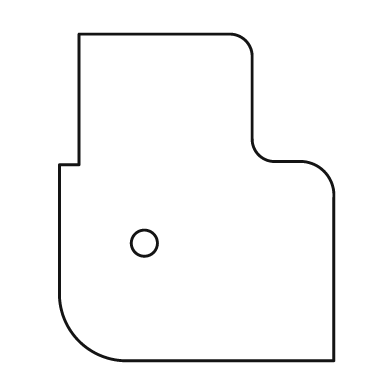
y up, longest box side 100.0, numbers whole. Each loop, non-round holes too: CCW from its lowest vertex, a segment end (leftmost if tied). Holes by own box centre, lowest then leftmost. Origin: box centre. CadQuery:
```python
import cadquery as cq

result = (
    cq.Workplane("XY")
    .moveTo(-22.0, -50.0)
    .lineTo(42.0, -50.0)
    .lineTo(42.0, 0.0)
    .threePointArc((39.0, 8.0), (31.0, 11.0))
    .lineTo(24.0, 11.0)
    .threePointArc((19.0, 13.0), (17.0, 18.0))
    .lineTo(17.0, 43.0)
    .threePointArc((15.0, 48.0), (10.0, 50.0))
    .lineTo(-36.0, 50.0)
    .lineTo(-36.0, 10.0)
    .lineTo(-42.0, 10.0)
    .lineTo(-42.0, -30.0)
    .threePointArc((-36.0, -44.0), (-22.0, -50.0))
    .close()
    .moveTo(-16.0, -14.0)
    .circle(4.0)
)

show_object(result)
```